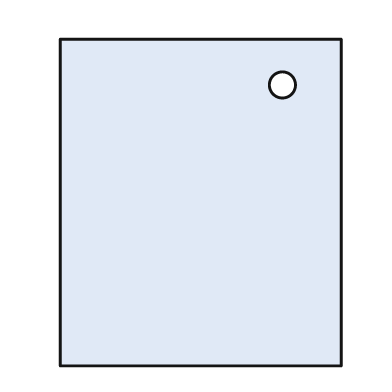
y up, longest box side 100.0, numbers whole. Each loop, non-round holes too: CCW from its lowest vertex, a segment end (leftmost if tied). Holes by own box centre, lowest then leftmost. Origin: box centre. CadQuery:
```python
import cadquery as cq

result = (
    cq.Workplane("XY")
    .moveTo(-43.0, -50.0)
    .lineTo(43.0, -50.0)
    .lineTo(43.0, 50.0)
    .lineTo(-43.0, 50.0)
    .close()
    .moveTo(25.0, 36.0)
    .circle(4.0)
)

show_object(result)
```